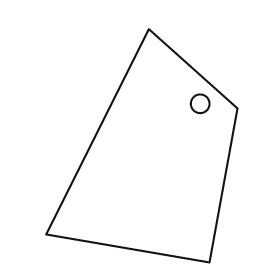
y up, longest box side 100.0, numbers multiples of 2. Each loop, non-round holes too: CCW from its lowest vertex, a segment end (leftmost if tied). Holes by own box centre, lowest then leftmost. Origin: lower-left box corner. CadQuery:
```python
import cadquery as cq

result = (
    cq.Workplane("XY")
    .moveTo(70.0, 0.0)
    .lineTo(82.0, 66.0)
    .lineTo(44.0, 100.0)
    .lineTo(0.0, 12.0)
    .close()
    .moveTo(66.0, 68.0)
    .circle(4.0)
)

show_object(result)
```